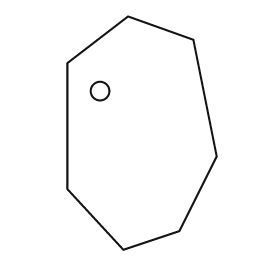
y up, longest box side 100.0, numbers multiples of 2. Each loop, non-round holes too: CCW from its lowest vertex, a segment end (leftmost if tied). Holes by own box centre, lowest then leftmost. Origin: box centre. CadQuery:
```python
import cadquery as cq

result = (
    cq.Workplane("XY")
    .moveTo(-8.0, -50.0)
    .lineTo(16.0, -42.0)
    .lineTo(32.0, -10.0)
    .lineTo(22.0, 40.0)
    .lineTo(-6.0, 50.0)
    .lineTo(-32.0, 30.0)
    .lineTo(-32.0, -24.0)
    .close()
    .moveTo(-18.0, 18.0)
    .circle(4.0)
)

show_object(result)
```